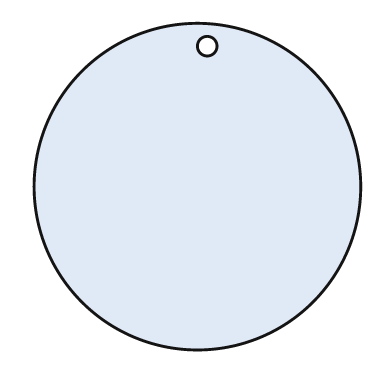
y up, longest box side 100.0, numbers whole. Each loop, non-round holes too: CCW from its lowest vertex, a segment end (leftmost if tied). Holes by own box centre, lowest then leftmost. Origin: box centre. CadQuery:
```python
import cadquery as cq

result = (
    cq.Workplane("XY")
    .moveTo(0.0, 0.0)
    .circle(50.0)
    .moveTo(3.0, 43.0)
    .circle(3.0)
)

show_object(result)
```